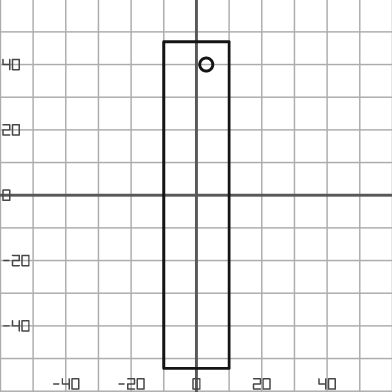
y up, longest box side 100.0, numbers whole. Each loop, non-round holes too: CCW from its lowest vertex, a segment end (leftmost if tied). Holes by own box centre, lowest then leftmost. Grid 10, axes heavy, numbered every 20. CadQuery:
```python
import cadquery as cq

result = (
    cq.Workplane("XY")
    .moveTo(-10.0, -53.0)
    .lineTo(10.0, -53.0)
    .lineTo(10.0, 47.0)
    .lineTo(-10.0, 47.0)
    .close()
    .moveTo(3.0, 40.0)
    .circle(2.0)
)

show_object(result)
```